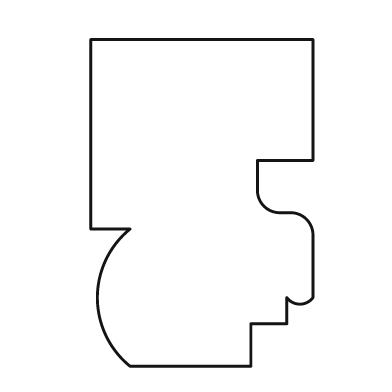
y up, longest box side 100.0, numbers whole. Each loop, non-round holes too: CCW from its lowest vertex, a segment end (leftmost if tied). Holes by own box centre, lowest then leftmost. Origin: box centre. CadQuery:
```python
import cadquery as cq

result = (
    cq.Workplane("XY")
    .moveTo(-22.0, -50.0)
    .lineTo(15.0, -50.0)
    .lineTo(15.0, -37.0)
    .lineTo(26.0, -37.0)
    .lineTo(26.0, -29.0)
    .threePointArc((30.0, -31.0), (34.0, -29.0))
    .lineTo(34.0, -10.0)
    .threePointArc((32.0, -5.0), (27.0, -3.0))
    .lineTo(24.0, -3.0)
    .threePointArc((19.0, -1.0), (17.0, 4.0))
    .lineTo(17.0, 13.0)
    .lineTo(34.0, 13.0)
    .lineTo(34.0, 50.0)
    .lineTo(-34.0, 50.0)
    .lineTo(-34.0, -8.0)
    .lineTo(-22.0, -8.0)
    .threePointArc((-32.0, -29.0), (-22.0, -50.0))
    .close()
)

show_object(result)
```